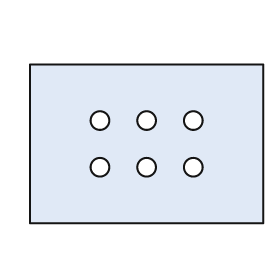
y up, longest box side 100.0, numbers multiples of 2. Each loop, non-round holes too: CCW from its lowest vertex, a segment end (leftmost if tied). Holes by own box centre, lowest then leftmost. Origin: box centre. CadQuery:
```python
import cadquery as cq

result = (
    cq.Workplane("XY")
    .moveTo(-50.0, -34.0)
    .lineTo(50.0, -34.0)
    .lineTo(50.0, 34.0)
    .lineTo(-50.0, 34.0)
    .close()
    .moveTo(-20.0, -10.0)
    .circle(4.0)
    .moveTo(0.0, -10.0)
    .circle(4.0)
    .moveTo(20.0, -10.0)
    .circle(4.0)
    .moveTo(-20.0, 10.0)
    .circle(4.0)
    .moveTo(0.0, 10.0)
    .circle(4.0)
    .moveTo(20.0, 10.0)
    .circle(4.0)
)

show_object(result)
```